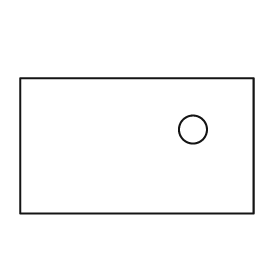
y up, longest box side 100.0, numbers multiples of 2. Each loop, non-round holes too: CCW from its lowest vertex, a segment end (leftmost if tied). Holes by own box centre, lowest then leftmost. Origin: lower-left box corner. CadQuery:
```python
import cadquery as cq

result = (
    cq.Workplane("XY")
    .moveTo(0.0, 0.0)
    .lineTo(100.0, 0.0)
    .lineTo(100.0, 58.0)
    .lineTo(0.0, 58.0)
    .close()
    .moveTo(74.0, 36.0)
    .circle(6.0)
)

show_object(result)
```